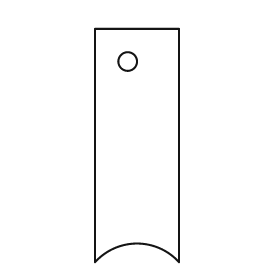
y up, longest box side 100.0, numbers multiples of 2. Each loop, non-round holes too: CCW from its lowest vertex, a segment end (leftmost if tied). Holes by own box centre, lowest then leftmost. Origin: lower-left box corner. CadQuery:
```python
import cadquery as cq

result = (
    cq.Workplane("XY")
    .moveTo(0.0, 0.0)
    .threePointArc((18.0, 8.0), (36.0, 0.0))
    .lineTo(36.0, 100.0)
    .lineTo(0.0, 100.0)
    .close()
    .moveTo(14.0, 86.0)
    .circle(4.0)
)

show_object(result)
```